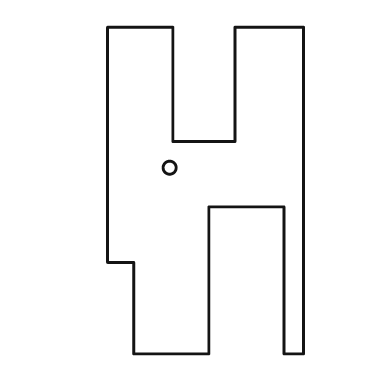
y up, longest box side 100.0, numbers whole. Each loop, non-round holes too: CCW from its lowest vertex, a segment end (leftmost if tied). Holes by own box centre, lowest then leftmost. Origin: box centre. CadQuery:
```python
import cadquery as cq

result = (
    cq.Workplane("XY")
    .moveTo(-22.0, -50.0)
    .lineTo(1.0, -50.0)
    .lineTo(1.0, -5.0)
    .lineTo(24.0, -5.0)
    .lineTo(24.0, -50.0)
    .lineTo(30.0, -50.0)
    .lineTo(30.0, 50.0)
    .lineTo(9.0, 50.0)
    .lineTo(9.0, 15.0)
    .lineTo(-10.0, 15.0)
    .lineTo(-10.0, 50.0)
    .lineTo(-30.0, 50.0)
    .lineTo(-30.0, -22.0)
    .lineTo(-22.0, -22.0)
    .close()
    .moveTo(-11.0, 7.0)
    .circle(2.0)
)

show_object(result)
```